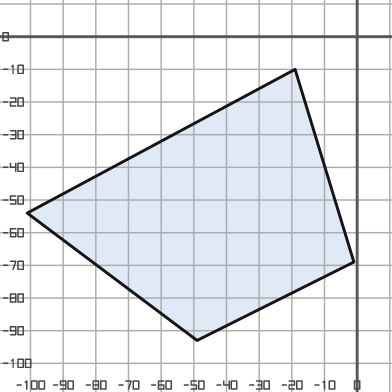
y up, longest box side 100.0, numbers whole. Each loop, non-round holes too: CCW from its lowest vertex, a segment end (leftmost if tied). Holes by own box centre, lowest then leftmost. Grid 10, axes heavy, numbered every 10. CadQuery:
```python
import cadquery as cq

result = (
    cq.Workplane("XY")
    .moveTo(-49.0, -93.0)
    .lineTo(-1.0, -69.0)
    .lineTo(-19.0, -10.0)
    .lineTo(-101.0, -54.0)
    .close()
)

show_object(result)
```